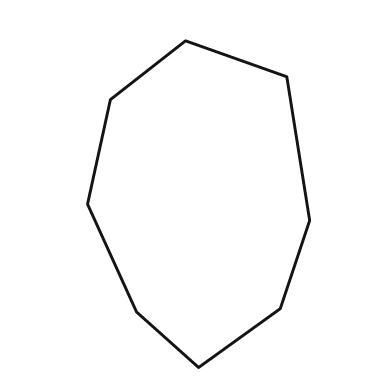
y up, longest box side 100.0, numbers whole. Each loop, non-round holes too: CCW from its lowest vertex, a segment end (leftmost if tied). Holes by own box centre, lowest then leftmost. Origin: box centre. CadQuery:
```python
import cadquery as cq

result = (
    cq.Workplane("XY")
    .moveTo(0.0, -50.0)
    .lineTo(25.0, -32.0)
    .lineTo(34.0, -5.0)
    .lineTo(27.0, 39.0)
    .lineTo(-4.0, 50.0)
    .lineTo(-27.0, 32.0)
    .lineTo(-34.0, 0.0)
    .lineTo(-19.0, -33.0)
    .close()
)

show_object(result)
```